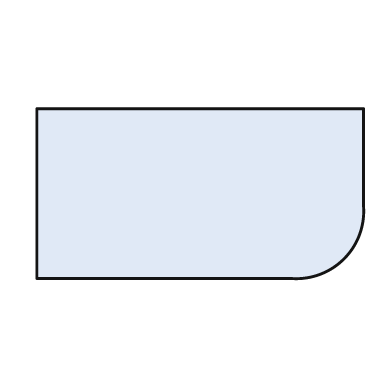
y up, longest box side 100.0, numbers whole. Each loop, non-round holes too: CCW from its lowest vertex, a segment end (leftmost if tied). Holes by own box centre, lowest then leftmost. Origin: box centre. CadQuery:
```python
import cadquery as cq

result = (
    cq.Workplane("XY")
    .moveTo(-50.0, -26.0)
    .lineTo(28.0, -26.0)
    .threePointArc((44.0, -20.0), (50.0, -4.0))
    .lineTo(50.0, 26.0)
    .lineTo(-50.0, 26.0)
    .close()
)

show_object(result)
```